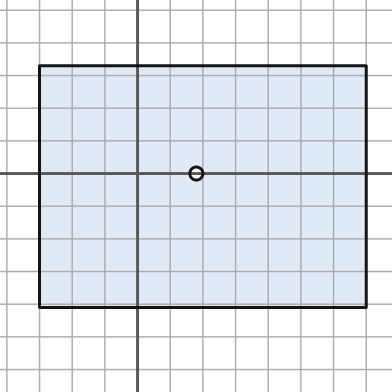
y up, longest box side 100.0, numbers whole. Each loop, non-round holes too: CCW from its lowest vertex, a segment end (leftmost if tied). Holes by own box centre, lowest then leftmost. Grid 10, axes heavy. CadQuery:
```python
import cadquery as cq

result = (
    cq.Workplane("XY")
    .moveTo(-30.0, -41.0)
    .lineTo(70.0, -41.0)
    .lineTo(70.0, 33.0)
    .lineTo(-30.0, 33.0)
    .close()
    .moveTo(18.0, 0.0)
    .circle(2.0)
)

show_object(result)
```